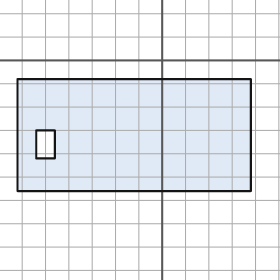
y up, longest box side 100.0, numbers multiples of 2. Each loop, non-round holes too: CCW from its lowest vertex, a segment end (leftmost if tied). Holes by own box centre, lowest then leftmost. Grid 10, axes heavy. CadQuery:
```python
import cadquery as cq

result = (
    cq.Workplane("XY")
    .moveTo(-62.0, -56.0)
    .lineTo(38.0, -56.0)
    .lineTo(38.0, -8.0)
    .lineTo(-62.0, -8.0)
    .close()
    .moveTo(-54.0, -42.0)
    .lineTo(-46.0, -42.0)
    .lineTo(-46.0, -30.0)
    .lineTo(-54.0, -30.0)
    .close()
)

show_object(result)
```